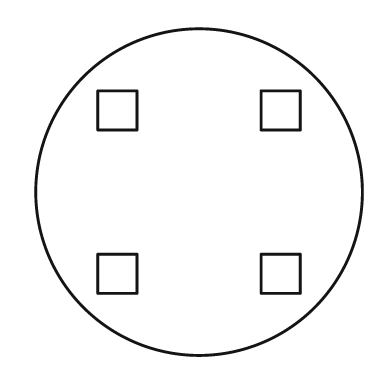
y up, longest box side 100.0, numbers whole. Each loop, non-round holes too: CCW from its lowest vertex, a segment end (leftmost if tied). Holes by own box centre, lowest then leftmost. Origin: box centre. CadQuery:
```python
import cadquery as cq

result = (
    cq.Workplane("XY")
    .moveTo(0.0, 0.0)
    .circle(50.0)
    .moveTo(-31.0, -31.0)
    .lineTo(-19.0, -31.0)
    .lineTo(-19.0, -19.0)
    .lineTo(-31.0, -19.0)
    .close()
    .moveTo(19.0, -31.0)
    .lineTo(31.0, -31.0)
    .lineTo(31.0, -19.0)
    .lineTo(19.0, -19.0)
    .close()
    .moveTo(-31.0, 19.0)
    .lineTo(-19.0, 19.0)
    .lineTo(-19.0, 31.0)
    .lineTo(-31.0, 31.0)
    .close()
    .moveTo(19.0, 19.0)
    .lineTo(31.0, 19.0)
    .lineTo(31.0, 31.0)
    .lineTo(19.0, 31.0)
    .close()
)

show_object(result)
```